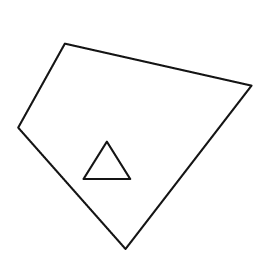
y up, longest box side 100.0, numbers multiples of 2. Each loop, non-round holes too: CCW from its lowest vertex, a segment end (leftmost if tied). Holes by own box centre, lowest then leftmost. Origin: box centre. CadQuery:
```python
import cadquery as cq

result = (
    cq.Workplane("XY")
    .moveTo(-4.0, -44.0)
    .lineTo(50.0, 26.0)
    .lineTo(-30.0, 44.0)
    .lineTo(-50.0, 8.0)
    .close()
    .moveTo(-22.0, -14.0)
    .lineTo(-2.0, -14.0)
    .lineTo(-12.0, 2.0)
    .close()
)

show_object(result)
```